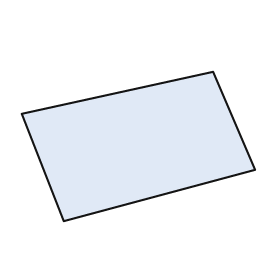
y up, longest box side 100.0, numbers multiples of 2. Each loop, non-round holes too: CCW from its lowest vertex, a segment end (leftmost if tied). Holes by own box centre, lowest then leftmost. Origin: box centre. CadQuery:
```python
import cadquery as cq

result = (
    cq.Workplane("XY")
    .moveTo(-32.0, -32.0)
    .lineTo(50.0, -10.0)
    .lineTo(32.0, 32.0)
    .lineTo(-50.0, 14.0)
    .close()
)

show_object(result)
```